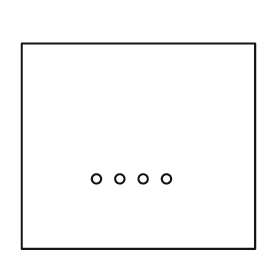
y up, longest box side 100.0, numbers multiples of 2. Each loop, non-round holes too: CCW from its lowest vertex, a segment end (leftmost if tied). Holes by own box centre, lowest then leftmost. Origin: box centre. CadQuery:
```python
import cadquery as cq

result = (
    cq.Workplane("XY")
    .moveTo(-50.0, -44.0)
    .lineTo(50.0, -44.0)
    .lineTo(50.0, 44.0)
    .lineTo(-50.0, 44.0)
    .close()
    .moveTo(-18.0, -14.0)
    .circle(2.0)
    .moveTo(-8.0, -14.0)
    .circle(2.0)
    .moveTo(2.0, -14.0)
    .circle(2.0)
    .moveTo(12.0, -14.0)
    .circle(2.0)
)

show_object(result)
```